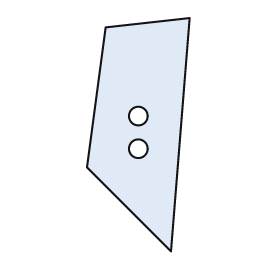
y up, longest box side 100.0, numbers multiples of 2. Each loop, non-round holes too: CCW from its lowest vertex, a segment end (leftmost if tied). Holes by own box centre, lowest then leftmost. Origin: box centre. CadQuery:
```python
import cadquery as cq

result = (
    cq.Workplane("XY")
    .moveTo(14.0, -50.0)
    .lineTo(22.0, 50.0)
    .lineTo(-14.0, 46.0)
    .lineTo(-22.0, -14.0)
    .close()
    .moveTo(0.0, -6.0)
    .circle(4.0)
    .moveTo(0.0, 8.0)
    .circle(4.0)
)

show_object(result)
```